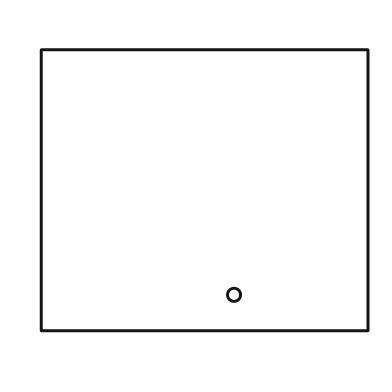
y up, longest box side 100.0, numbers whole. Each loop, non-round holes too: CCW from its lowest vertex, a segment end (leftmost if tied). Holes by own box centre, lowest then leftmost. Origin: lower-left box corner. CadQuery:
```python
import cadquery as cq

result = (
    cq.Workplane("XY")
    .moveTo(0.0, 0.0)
    .lineTo(100.0, 0.0)
    .lineTo(100.0, 86.0)
    .lineTo(0.0, 86.0)
    .close()
    .moveTo(59.0, 11.0)
    .circle(2.0)
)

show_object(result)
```